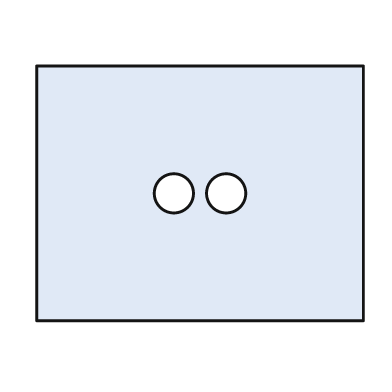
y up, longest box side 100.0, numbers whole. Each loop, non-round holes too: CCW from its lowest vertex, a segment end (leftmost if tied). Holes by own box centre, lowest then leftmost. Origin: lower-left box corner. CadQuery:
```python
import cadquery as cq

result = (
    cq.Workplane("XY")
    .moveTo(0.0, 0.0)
    .lineTo(100.0, 0.0)
    .lineTo(100.0, 78.0)
    .lineTo(0.0, 78.0)
    .close()
    .moveTo(42.0, 39.0)
    .circle(6.0)
    .moveTo(58.0, 39.0)
    .circle(6.0)
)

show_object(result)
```